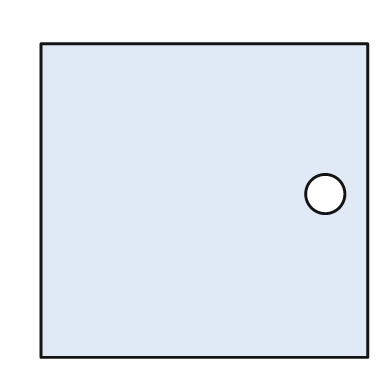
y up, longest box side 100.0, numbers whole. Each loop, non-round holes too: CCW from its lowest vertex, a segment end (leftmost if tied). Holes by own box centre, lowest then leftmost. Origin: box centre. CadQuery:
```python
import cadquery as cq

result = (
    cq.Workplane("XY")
    .moveTo(-50.0, -48.0)
    .lineTo(50.0, -48.0)
    .lineTo(50.0, 48.0)
    .lineTo(-50.0, 48.0)
    .close()
    .moveTo(37.0, 2.0)
    .circle(6.0)
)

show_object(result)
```